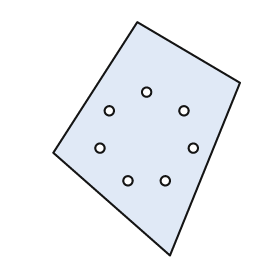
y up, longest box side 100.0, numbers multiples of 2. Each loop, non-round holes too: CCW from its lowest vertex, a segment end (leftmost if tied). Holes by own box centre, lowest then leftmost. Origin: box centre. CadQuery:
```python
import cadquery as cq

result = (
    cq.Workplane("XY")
    .moveTo(10.0, -50.0)
    .lineTo(40.0, 24.0)
    .lineTo(-4.0, 50.0)
    .lineTo(-40.0, -6.0)
    .close()
    .moveTo(-8.0, -18.0)
    .circle(2.0)
    .moveTo(8.0, -18.0)
    .circle(2.0)
    .moveTo(-20.0, -4.0)
    .circle(2.0)
    .moveTo(20.0, -4.0)
    .circle(2.0)
    .moveTo(-16.0, 12.0)
    .circle(2.0)
    .moveTo(16.0, 12.0)
    .circle(2.0)
    .moveTo(0.0, 20.0)
    .circle(2.0)
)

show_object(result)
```